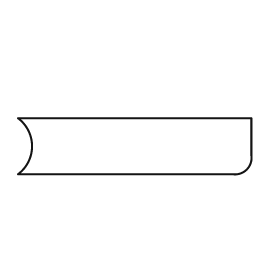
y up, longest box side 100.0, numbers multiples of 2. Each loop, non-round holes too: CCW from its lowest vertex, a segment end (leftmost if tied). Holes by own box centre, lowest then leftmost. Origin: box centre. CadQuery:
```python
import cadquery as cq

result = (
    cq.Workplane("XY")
    .moveTo(-50.0, -12.0)
    .lineTo(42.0, -12.0)
    .threePointArc((48.0, -10.0), (50.0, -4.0))
    .lineTo(50.0, 12.0)
    .lineTo(-50.0, 12.0)
    .threePointArc((-44.0, 0.0), (-50.0, -12.0))
    .close()
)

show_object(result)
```